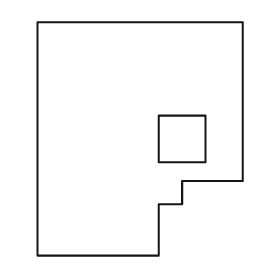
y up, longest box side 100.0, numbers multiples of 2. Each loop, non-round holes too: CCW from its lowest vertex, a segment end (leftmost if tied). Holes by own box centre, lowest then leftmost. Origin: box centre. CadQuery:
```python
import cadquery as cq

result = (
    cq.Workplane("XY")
    .moveTo(-44.0, -50.0)
    .lineTo(8.0, -50.0)
    .lineTo(8.0, -28.0)
    .lineTo(18.0, -28.0)
    .lineTo(18.0, -18.0)
    .lineTo(44.0, -18.0)
    .lineTo(44.0, 50.0)
    .lineTo(-44.0, 50.0)
    .close()
    .moveTo(8.0, -10.0)
    .lineTo(28.0, -10.0)
    .lineTo(28.0, 10.0)
    .lineTo(8.0, 10.0)
    .close()
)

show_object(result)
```